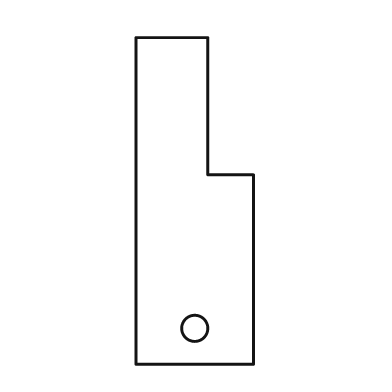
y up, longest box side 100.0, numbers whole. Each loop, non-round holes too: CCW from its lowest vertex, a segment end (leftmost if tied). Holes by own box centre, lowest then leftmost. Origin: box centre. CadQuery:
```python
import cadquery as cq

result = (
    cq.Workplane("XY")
    .moveTo(-18.0, -50.0)
    .lineTo(18.0, -50.0)
    .lineTo(18.0, 8.0)
    .lineTo(4.0, 8.0)
    .lineTo(4.0, 50.0)
    .lineTo(-18.0, 50.0)
    .close()
    .moveTo(0.0, -39.0)
    .circle(4.0)
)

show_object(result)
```